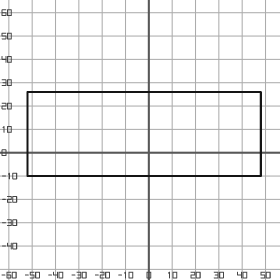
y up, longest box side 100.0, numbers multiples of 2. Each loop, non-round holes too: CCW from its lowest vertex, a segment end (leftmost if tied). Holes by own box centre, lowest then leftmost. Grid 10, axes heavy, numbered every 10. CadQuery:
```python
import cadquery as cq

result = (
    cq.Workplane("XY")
    .moveTo(-52.0, -10.0)
    .lineTo(48.0, -10.0)
    .lineTo(48.0, 26.0)
    .lineTo(-52.0, 26.0)
    .close()
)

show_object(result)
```